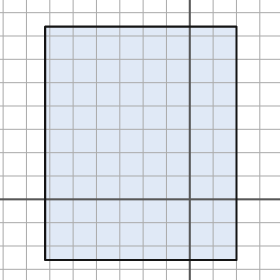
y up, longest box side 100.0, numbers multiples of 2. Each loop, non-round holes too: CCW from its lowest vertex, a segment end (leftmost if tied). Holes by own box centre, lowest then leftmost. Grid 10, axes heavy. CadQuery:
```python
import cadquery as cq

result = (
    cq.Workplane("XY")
    .moveTo(-62.0, -26.0)
    .lineTo(20.0, -26.0)
    .lineTo(20.0, 74.0)
    .lineTo(-62.0, 74.0)
    .close()
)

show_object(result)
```